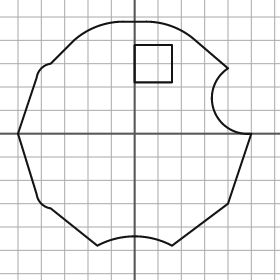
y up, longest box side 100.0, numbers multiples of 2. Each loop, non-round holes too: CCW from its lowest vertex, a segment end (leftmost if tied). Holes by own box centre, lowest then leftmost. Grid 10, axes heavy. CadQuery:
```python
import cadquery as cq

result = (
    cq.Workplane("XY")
    .moveTo(-16.0, -48.0)
    .threePointArc((0.0, -44.0), (16.0, -48.0))
    .lineTo(40.0, -30.0)
    .lineTo(50.0, 0.0)
    .threePointArc((34.0, 10.0), (40.0, 28.0))
    .lineTo(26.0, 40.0)
    .threePointArc((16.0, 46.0), (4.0, 48.0))
    .lineTo(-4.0, 48.0)
    .threePointArc((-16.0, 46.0), (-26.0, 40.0))
    .lineTo(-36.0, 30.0)
    .threePointArc((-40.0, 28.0), (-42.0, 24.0))
    .lineTo(-50.0, 0.0)
    .lineTo(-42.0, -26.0)
    .threePointArc((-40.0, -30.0), (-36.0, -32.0))
    .close()
    .moveTo(0.0, 22.0)
    .lineTo(16.0, 22.0)
    .lineTo(16.0, 38.0)
    .lineTo(0.0, 38.0)
    .close()
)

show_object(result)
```